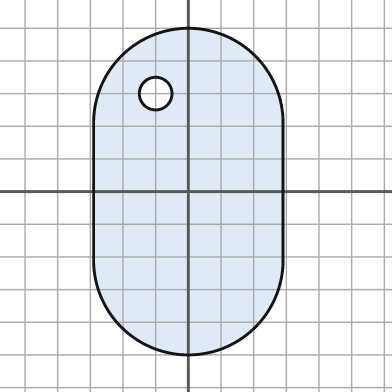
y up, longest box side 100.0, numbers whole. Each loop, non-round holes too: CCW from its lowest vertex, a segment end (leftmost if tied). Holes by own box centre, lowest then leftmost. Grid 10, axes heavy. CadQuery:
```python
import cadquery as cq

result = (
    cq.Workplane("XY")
    .moveTo(-29.0, -21.0)
    .threePointArc((0.0, -50.0), (29.0, -21.0))
    .lineTo(29.0, 21.0)
    .threePointArc((0.0, 50.0), (-29.0, 21.0))
    .close()
    .moveTo(-10.0, 30.0)
    .circle(5.0)
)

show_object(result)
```